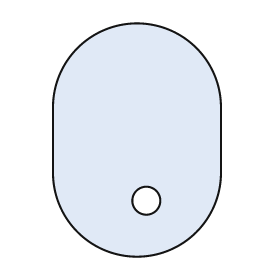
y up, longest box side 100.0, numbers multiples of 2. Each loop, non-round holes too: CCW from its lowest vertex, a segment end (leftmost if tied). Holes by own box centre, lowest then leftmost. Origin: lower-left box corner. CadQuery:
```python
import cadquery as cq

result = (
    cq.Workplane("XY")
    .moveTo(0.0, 36.0)
    .threePointArc((36.0, 0.0), (72.0, 36.0))
    .lineTo(72.0, 64.0)
    .threePointArc((36.0, 100.0), (0.0, 64.0))
    .close()
    .moveTo(40.0, 24.0)
    .circle(6.0)
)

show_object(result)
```